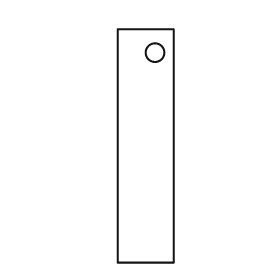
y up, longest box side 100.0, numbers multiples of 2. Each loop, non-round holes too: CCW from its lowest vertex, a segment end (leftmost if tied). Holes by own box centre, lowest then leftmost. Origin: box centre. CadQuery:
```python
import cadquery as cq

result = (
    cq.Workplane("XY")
    .moveTo(-12.0, -50.0)
    .lineTo(12.0, -50.0)
    .lineTo(12.0, 50.0)
    .lineTo(-12.0, 50.0)
    .close()
    .moveTo(4.0, 40.0)
    .circle(4.0)
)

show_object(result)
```